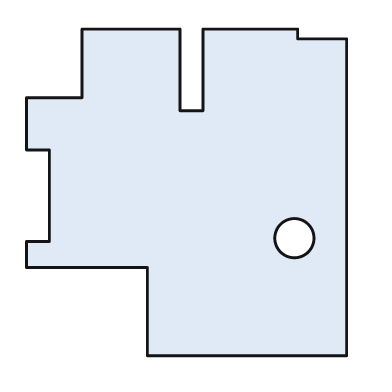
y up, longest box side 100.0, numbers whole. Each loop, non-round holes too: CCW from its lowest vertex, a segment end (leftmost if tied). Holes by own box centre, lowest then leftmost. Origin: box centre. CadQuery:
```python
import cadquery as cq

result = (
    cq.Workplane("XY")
    .moveTo(-12.0, -50.0)
    .lineTo(49.0, -50.0)
    .lineTo(49.0, 47.0)
    .lineTo(34.0, 47.0)
    .lineTo(34.0, 50.0)
    .lineTo(5.0, 50.0)
    .lineTo(5.0, 25.0)
    .lineTo(-2.0, 25.0)
    .lineTo(-2.0, 50.0)
    .lineTo(-32.0, 50.0)
    .lineTo(-32.0, 29.0)
    .lineTo(-49.0, 29.0)
    .lineTo(-49.0, 13.0)
    .lineTo(-42.0, 13.0)
    .lineTo(-42.0, -15.0)
    .lineTo(-49.0, -15.0)
    .lineTo(-49.0, -23.0)
    .lineTo(-12.0, -23.0)
    .close()
    .moveTo(33.0, -14.0)
    .circle(6.0)
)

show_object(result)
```